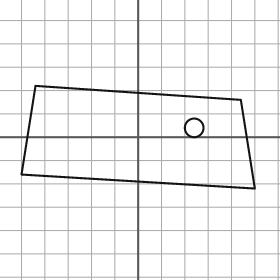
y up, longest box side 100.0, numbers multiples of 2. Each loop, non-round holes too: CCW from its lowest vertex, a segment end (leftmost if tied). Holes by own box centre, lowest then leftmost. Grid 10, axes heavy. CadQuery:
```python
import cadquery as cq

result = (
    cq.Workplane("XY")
    .moveTo(50.0, -22.0)
    .lineTo(44.0, 16.0)
    .lineTo(-44.0, 22.0)
    .lineTo(-50.0, -16.0)
    .close()
    .moveTo(24.0, 4.0)
    .circle(4.0)
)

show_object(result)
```